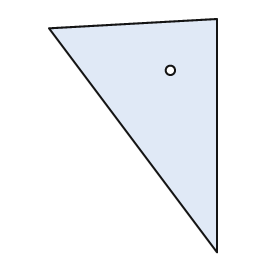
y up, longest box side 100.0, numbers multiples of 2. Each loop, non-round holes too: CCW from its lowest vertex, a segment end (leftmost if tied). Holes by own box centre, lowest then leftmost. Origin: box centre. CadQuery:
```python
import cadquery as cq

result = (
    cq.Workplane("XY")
    .moveTo(36.0, -50.0)
    .lineTo(36.0, 50.0)
    .lineTo(-36.0, 46.0)
    .close()
    .moveTo(16.0, 28.0)
    .circle(2.0)
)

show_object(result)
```